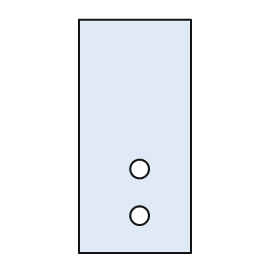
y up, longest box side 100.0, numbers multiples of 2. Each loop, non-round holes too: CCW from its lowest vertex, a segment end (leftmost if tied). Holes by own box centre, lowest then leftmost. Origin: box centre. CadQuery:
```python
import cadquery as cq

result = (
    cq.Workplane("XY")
    .moveTo(-24.0, -50.0)
    .lineTo(24.0, -50.0)
    .lineTo(24.0, 50.0)
    .lineTo(-24.0, 50.0)
    .close()
    .moveTo(2.0, -34.0)
    .circle(4.0)
    .moveTo(2.0, -14.0)
    .circle(4.0)
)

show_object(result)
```